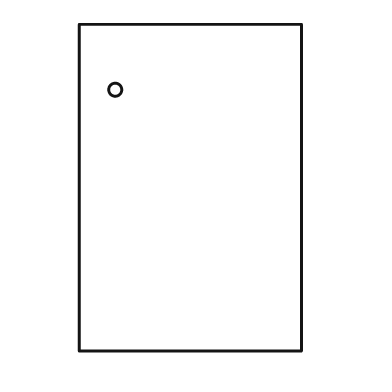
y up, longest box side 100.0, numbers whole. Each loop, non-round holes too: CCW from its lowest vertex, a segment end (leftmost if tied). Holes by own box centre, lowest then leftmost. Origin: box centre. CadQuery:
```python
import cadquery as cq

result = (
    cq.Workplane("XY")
    .moveTo(-34.0, -50.0)
    .lineTo(34.0, -50.0)
    .lineTo(34.0, 50.0)
    .lineTo(-34.0, 50.0)
    .close()
    .moveTo(-23.0, 30.0)
    .circle(2.0)
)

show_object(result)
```